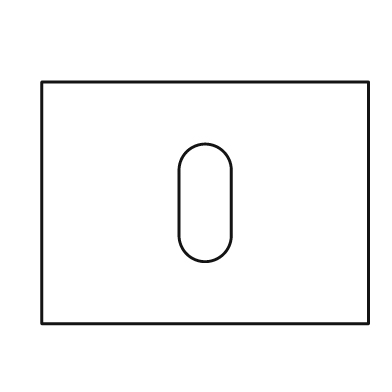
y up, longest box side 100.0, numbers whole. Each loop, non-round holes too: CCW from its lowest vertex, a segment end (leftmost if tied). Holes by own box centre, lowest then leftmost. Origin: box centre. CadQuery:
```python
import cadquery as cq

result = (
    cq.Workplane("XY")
    .moveTo(-50.0, -37.0)
    .lineTo(50.0, -37.0)
    .lineTo(50.0, 37.0)
    .lineTo(-50.0, 37.0)
    .close()
    .moveTo(-8.0, -10.0)
    .threePointArc((0.0, -18.0), (8.0, -10.0))
    .lineTo(8.0, 10.0)
    .threePointArc((0.0, 18.0), (-8.0, 10.0))
    .close()
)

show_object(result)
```